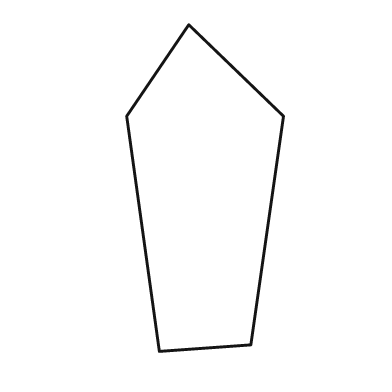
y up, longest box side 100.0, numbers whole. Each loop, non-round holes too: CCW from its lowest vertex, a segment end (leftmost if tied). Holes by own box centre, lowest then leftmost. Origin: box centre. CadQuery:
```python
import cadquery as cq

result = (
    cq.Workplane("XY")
    .moveTo(-14.0, -50.0)
    .lineTo(14.0, -48.0)
    .lineTo(24.0, 22.0)
    .lineTo(-5.0, 50.0)
    .lineTo(-24.0, 22.0)
    .close()
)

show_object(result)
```